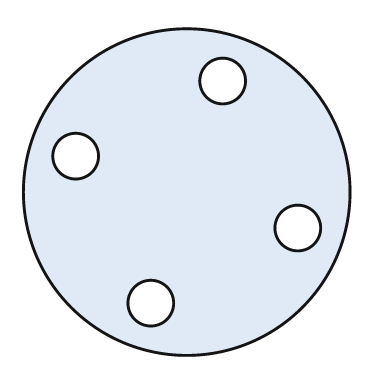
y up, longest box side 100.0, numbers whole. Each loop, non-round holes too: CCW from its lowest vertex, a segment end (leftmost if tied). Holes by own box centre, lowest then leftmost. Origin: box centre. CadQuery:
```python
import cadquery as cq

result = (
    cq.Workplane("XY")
    .moveTo(0.0, 0.0)
    .circle(50.0)
    .moveTo(-11.0, -34.0)
    .circle(7.0)
    .moveTo(34.0, -11.0)
    .circle(7.0)
    .moveTo(-34.0, 11.0)
    .circle(7.0)
    .moveTo(11.0, 34.0)
    .circle(7.0)
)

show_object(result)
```